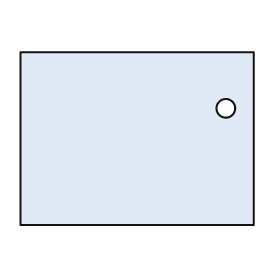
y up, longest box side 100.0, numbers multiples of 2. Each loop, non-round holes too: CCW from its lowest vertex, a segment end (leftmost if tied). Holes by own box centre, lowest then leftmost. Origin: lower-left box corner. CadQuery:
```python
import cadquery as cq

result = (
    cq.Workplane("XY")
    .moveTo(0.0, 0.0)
    .lineTo(100.0, 0.0)
    .lineTo(100.0, 74.0)
    .lineTo(0.0, 74.0)
    .close()
    .moveTo(88.0, 50.0)
    .circle(4.0)
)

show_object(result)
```